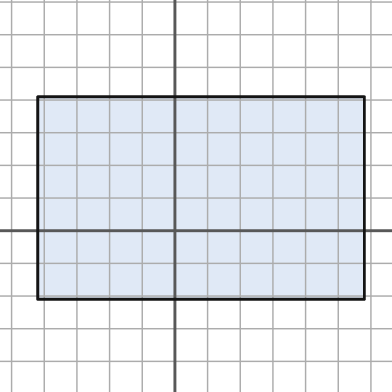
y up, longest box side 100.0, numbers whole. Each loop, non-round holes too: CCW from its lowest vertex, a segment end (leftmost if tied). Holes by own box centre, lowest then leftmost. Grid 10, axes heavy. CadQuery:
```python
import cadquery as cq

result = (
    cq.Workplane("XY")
    .moveTo(-42.0, -21.0)
    .lineTo(58.0, -21.0)
    .lineTo(58.0, 41.0)
    .lineTo(-42.0, 41.0)
    .close()
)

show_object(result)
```